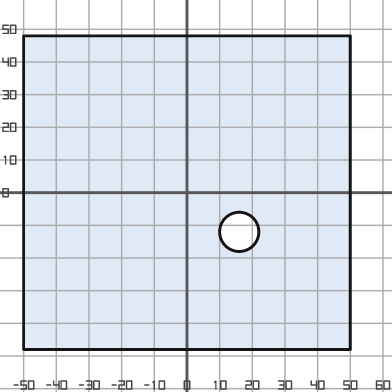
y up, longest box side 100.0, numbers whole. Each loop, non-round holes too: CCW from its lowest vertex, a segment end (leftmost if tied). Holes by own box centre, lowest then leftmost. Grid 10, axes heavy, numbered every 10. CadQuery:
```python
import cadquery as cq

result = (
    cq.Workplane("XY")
    .moveTo(-50.0, -48.0)
    .lineTo(50.0, -48.0)
    .lineTo(50.0, 48.0)
    .lineTo(-50.0, 48.0)
    .close()
    .moveTo(16.0, -12.0)
    .circle(6.0)
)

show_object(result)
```